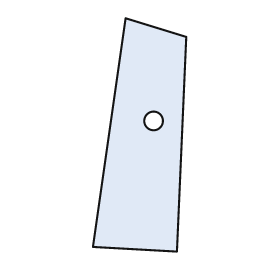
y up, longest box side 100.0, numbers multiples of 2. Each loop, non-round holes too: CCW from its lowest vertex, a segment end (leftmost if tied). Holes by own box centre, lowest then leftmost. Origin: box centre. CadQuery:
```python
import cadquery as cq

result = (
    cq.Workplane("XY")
    .moveTo(16.0, -50.0)
    .lineTo(20.0, 42.0)
    .lineTo(-6.0, 50.0)
    .lineTo(-20.0, -48.0)
    .close()
    .moveTo(6.0, 6.0)
    .circle(4.0)
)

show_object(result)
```